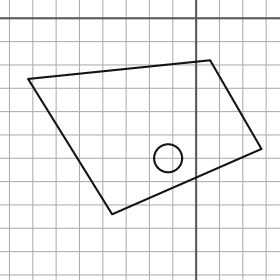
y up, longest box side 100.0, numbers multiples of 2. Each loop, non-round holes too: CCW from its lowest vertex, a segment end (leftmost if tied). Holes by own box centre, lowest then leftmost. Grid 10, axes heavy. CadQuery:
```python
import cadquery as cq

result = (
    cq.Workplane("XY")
    .moveTo(-36.0, -84.0)
    .lineTo(28.0, -56.0)
    .lineTo(6.0, -18.0)
    .lineTo(-72.0, -26.0)
    .close()
    .moveTo(-12.0, -60.0)
    .circle(6.0)
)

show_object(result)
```